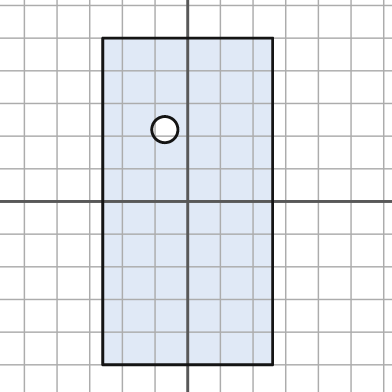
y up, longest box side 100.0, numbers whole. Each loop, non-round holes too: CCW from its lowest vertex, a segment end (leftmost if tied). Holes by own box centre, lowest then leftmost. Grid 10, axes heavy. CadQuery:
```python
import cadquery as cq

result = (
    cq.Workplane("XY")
    .moveTo(-26.0, -50.0)
    .lineTo(26.0, -50.0)
    .lineTo(26.0, 50.0)
    .lineTo(-26.0, 50.0)
    .close()
    .moveTo(-7.0, 22.0)
    .circle(4.0)
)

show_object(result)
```